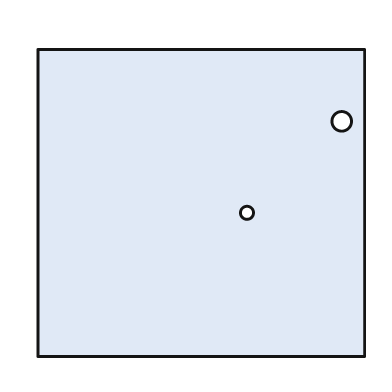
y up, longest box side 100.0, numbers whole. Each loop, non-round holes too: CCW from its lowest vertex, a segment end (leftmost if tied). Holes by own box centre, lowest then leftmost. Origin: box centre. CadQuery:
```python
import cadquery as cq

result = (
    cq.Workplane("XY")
    .moveTo(-50.0, -47.0)
    .lineTo(50.0, -47.0)
    .lineTo(50.0, 47.0)
    .lineTo(-50.0, 47.0)
    .close()
    .moveTo(14.0, -3.0)
    .circle(2.0)
    .moveTo(43.0, 25.0)
    .circle(3.0)
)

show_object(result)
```